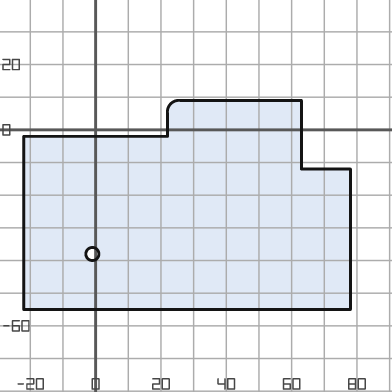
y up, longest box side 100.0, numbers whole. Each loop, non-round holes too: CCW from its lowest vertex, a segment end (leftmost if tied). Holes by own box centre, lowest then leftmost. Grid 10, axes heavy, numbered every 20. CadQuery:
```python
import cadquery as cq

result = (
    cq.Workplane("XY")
    .moveTo(-22.0, -55.0)
    .lineTo(78.0, -55.0)
    .lineTo(78.0, -12.0)
    .lineTo(63.0, -12.0)
    .lineTo(63.0, 9.0)
    .lineTo(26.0, 9.0)
    .threePointArc((23.0, 8.0), (22.0, 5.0))
    .lineTo(22.0, -2.0)
    .lineTo(-22.0, -2.0)
    .close()
    .moveTo(-1.0, -38.0)
    .circle(2.0)
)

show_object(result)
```